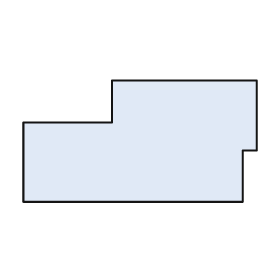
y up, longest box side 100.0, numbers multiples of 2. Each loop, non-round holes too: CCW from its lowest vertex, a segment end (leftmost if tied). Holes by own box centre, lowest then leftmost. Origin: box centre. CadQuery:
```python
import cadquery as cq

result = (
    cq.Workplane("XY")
    .moveTo(-50.0, -26.0)
    .lineTo(44.0, -26.0)
    .lineTo(44.0, -4.0)
    .lineTo(50.0, -4.0)
    .lineTo(50.0, 26.0)
    .lineTo(-12.0, 26.0)
    .lineTo(-12.0, 8.0)
    .lineTo(-50.0, 8.0)
    .close()
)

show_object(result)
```